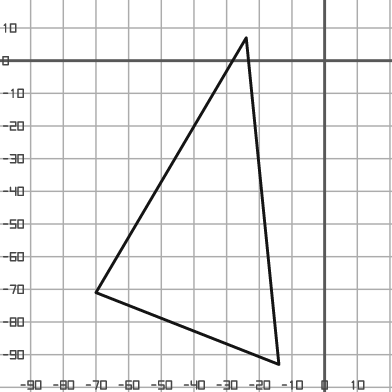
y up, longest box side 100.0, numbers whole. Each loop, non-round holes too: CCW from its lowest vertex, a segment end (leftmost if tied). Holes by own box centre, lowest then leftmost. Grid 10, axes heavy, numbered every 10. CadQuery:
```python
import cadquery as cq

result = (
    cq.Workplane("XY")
    .moveTo(-14.0, -93.0)
    .lineTo(-24.0, 7.0)
    .lineTo(-70.0, -71.0)
    .close()
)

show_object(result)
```